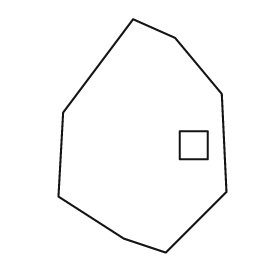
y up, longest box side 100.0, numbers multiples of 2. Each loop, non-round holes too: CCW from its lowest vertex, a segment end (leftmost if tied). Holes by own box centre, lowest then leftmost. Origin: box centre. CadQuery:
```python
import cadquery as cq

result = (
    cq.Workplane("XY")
    .moveTo(10.0, -50.0)
    .lineTo(36.0, -24.0)
    .lineTo(34.0, 18.0)
    .lineTo(14.0, 42.0)
    .lineTo(-4.0, 50.0)
    .lineTo(-34.0, 10.0)
    .lineTo(-36.0, -26.0)
    .lineTo(-8.0, -44.0)
    .close()
    .moveTo(16.0, -10.0)
    .lineTo(28.0, -10.0)
    .lineTo(28.0, 2.0)
    .lineTo(16.0, 2.0)
    .close()
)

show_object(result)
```